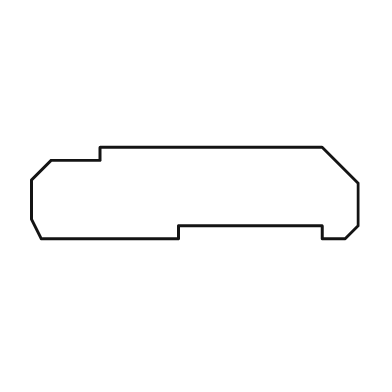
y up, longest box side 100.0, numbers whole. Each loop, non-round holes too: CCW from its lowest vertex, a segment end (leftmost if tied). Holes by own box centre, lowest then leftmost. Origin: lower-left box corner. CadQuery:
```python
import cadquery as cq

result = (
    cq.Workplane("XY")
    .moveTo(3.0, 0.0)
    .lineTo(45.0, 0.0)
    .lineTo(45.0, 4.0)
    .lineTo(89.0, 4.0)
    .lineTo(89.0, 0.0)
    .lineTo(96.0, 0.0)
    .lineTo(100.0, 4.0)
    .lineTo(100.0, 17.0)
    .lineTo(89.0, 28.0)
    .lineTo(21.0, 28.0)
    .lineTo(21.0, 24.0)
    .lineTo(6.0, 24.0)
    .lineTo(0.0, 18.0)
    .lineTo(0.0, 6.0)
    .close()
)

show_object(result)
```